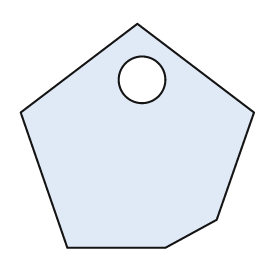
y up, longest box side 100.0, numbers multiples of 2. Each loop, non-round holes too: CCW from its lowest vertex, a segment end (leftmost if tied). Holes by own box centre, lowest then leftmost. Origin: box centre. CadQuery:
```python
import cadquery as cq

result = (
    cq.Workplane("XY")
    .moveTo(-30.0, -48.0)
    .lineTo(12.0, -48.0)
    .lineTo(34.0, -36.0)
    .lineTo(50.0, 10.0)
    .lineTo(0.0, 48.0)
    .lineTo(-50.0, 10.0)
    .close()
    .moveTo(2.0, 24.0)
    .circle(10.0)
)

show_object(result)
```